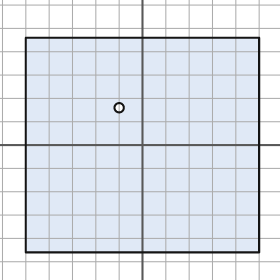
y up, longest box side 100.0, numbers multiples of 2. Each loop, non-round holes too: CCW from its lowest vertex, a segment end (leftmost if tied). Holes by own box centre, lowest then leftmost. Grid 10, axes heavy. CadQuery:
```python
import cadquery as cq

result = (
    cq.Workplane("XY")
    .moveTo(-50.0, -46.0)
    .lineTo(50.0, -46.0)
    .lineTo(50.0, 46.0)
    .lineTo(-50.0, 46.0)
    .close()
    .moveTo(-10.0, 16.0)
    .circle(2.0)
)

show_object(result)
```